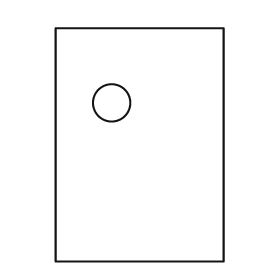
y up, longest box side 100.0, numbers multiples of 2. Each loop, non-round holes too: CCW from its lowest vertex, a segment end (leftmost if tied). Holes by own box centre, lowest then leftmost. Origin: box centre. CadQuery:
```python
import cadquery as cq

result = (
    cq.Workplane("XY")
    .moveTo(-36.0, -50.0)
    .lineTo(36.0, -50.0)
    .lineTo(36.0, 50.0)
    .lineTo(-36.0, 50.0)
    .close()
    .moveTo(-12.0, 18.0)
    .circle(8.0)
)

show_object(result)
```